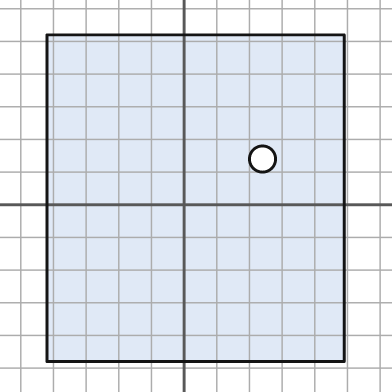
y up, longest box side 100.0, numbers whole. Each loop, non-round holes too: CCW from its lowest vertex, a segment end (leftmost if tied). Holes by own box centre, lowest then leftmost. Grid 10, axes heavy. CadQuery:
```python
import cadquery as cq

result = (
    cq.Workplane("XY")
    .moveTo(-42.0, -48.0)
    .lineTo(49.0, -48.0)
    .lineTo(49.0, 52.0)
    .lineTo(-42.0, 52.0)
    .close()
    .moveTo(24.0, 14.0)
    .circle(4.0)
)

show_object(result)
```